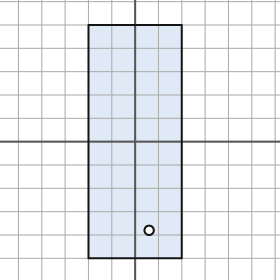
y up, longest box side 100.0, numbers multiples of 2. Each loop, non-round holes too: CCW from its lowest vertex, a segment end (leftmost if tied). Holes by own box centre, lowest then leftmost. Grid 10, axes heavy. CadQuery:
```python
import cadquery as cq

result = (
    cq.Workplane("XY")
    .moveTo(-20.0, -50.0)
    .lineTo(20.0, -50.0)
    .lineTo(20.0, 50.0)
    .lineTo(-20.0, 50.0)
    .close()
    .moveTo(6.0, -38.0)
    .circle(2.0)
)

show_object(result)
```